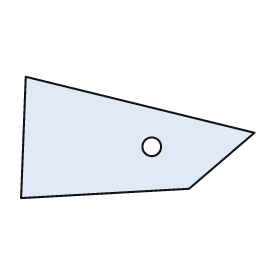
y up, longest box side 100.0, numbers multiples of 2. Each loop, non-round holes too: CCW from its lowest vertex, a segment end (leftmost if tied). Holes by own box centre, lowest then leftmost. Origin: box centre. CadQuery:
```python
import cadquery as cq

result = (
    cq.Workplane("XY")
    .moveTo(-50.0, -26.0)
    .lineTo(22.0, -22.0)
    .lineTo(50.0, 2.0)
    .lineTo(-48.0, 26.0)
    .close()
    .moveTo(6.0, -4.0)
    .circle(4.0)
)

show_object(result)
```